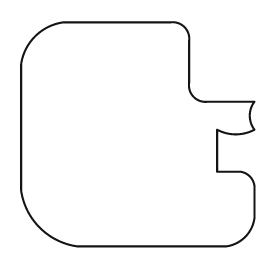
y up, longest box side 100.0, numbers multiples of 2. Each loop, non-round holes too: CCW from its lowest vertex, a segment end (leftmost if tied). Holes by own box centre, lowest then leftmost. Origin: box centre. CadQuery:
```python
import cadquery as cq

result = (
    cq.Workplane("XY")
    .moveTo(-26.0, -48.0)
    .lineTo(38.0, -48.0)
    .threePointArc((46.0, -44.0), (50.0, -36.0))
    .lineTo(50.0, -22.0)
    .threePointArc((48.0, -18.0), (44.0, -16.0))
    .lineTo(34.0, -16.0)
    .lineTo(34.0, 2.0)
    .threePointArc((42.0, 0.0), (50.0, 2.0))
    .threePointArc((48.0, 8.0), (50.0, 14.0))
    .lineTo(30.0, 14.0)
    .threePointArc((24.0, 16.0), (22.0, 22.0))
    .lineTo(22.0, 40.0)
    .threePointArc((20.0, 46.0), (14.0, 48.0))
    .lineTo(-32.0, 48.0)
    .threePointArc((-44.0, 42.0), (-50.0, 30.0))
    .lineTo(-50.0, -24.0)
    .threePointArc((-42.0, -40.0), (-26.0, -48.0))
    .close()
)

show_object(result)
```